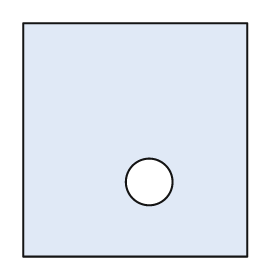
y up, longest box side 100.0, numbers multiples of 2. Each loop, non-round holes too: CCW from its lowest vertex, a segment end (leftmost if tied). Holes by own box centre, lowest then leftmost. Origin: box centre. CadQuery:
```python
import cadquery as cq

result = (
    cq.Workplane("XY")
    .moveTo(-48.0, -50.0)
    .lineTo(48.0, -50.0)
    .lineTo(48.0, 50.0)
    .lineTo(-48.0, 50.0)
    .close()
    .moveTo(6.0, -18.0)
    .circle(10.0)
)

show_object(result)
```